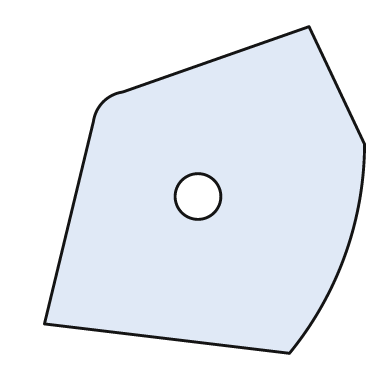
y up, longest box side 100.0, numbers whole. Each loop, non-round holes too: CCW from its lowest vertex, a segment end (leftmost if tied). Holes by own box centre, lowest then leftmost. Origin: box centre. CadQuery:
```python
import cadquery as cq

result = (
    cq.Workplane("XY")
    .moveTo(26.0, -50.0)
    .threePointArc((43.0, -20.0), (49.0, 14.0))
    .lineTo(32.0, 50.0)
    .lineTo(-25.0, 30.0)
    .threePointArc((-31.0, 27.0), (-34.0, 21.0))
    .lineTo(-49.0, -41.0)
    .close()
    .moveTo(-2.0, -2.0)
    .circle(7.0)
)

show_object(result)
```